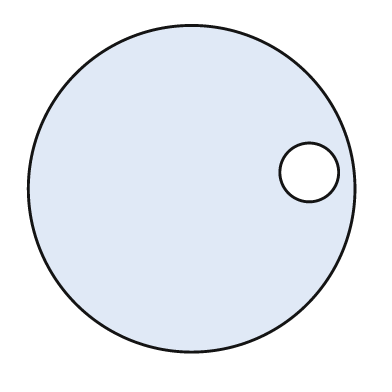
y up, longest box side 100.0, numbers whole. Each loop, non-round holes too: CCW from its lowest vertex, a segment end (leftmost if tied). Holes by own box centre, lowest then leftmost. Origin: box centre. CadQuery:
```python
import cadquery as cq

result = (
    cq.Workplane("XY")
    .moveTo(0.0, 0.0)
    .circle(50.0)
    .moveTo(36.0, 5.0)
    .circle(9.0)
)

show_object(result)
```